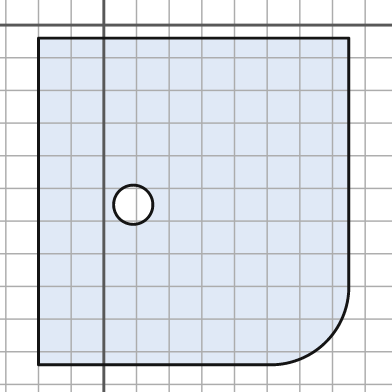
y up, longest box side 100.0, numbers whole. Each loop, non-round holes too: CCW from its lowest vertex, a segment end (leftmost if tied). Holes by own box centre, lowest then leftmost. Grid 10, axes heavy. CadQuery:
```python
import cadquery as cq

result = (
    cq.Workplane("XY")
    .moveTo(-20.0, -104.0)
    .lineTo(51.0, -104.0)
    .threePointArc((68.0, -97.0), (75.0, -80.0))
    .lineTo(75.0, -4.0)
    .lineTo(-20.0, -4.0)
    .close()
    .moveTo(9.0, -55.0)
    .circle(6.0)
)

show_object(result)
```